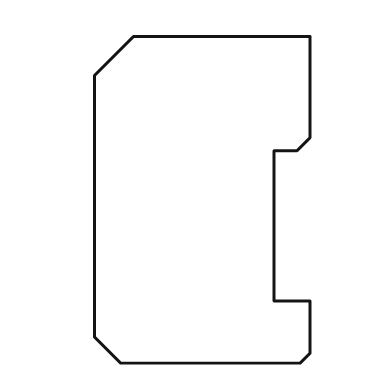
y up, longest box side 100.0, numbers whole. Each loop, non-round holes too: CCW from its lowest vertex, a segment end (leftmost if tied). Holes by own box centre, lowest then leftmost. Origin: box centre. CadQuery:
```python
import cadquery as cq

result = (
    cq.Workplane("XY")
    .moveTo(-25.0, -50.0)
    .lineTo(30.0, -50.0)
    .lineTo(33.0, -47.0)
    .lineTo(33.0, -31.0)
    .lineTo(22.0, -31.0)
    .lineTo(22.0, 15.0)
    .lineTo(29.0, 15.0)
    .lineTo(33.0, 19.0)
    .lineTo(33.0, 50.0)
    .lineTo(-21.0, 50.0)
    .lineTo(-33.0, 38.0)
    .lineTo(-33.0, -42.0)
    .close()
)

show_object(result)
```